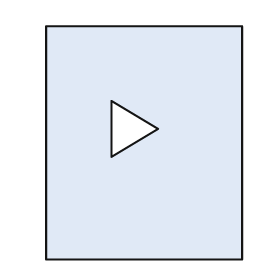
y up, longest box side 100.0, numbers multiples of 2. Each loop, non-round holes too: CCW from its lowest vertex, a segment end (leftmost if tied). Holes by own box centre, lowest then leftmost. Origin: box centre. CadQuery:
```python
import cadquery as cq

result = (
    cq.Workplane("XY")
    .moveTo(-42.0, -50.0)
    .lineTo(42.0, -50.0)
    .lineTo(42.0, 50.0)
    .lineTo(-42.0, 50.0)
    .close()
    .moveTo(-14.0, -6.0)
    .lineTo(6.0, 6.0)
    .lineTo(-14.0, 18.0)
    .close()
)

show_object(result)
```